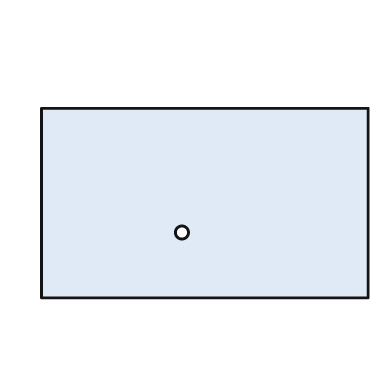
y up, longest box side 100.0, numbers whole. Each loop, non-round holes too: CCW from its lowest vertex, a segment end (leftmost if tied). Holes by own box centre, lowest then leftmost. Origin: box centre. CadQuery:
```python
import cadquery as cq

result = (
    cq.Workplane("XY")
    .moveTo(-50.0, -29.0)
    .lineTo(50.0, -29.0)
    .lineTo(50.0, 29.0)
    .lineTo(-50.0, 29.0)
    .close()
    .moveTo(-7.0, -9.0)
    .circle(2.0)
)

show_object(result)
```